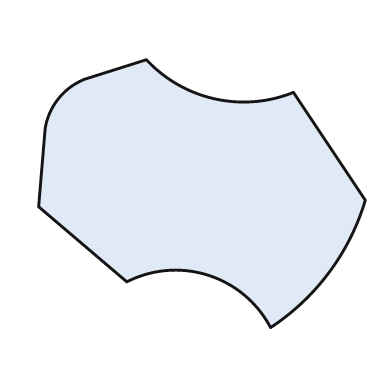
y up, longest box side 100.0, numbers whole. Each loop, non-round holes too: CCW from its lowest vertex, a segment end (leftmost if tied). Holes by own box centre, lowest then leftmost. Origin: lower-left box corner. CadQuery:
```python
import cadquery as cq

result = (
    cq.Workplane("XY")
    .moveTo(71.0, 0.0)
    .threePointArc((89.0, 17.0), (100.0, 39.0))
    .lineTo(78.0, 72.0)
    .threePointArc((54.0, 70.0), (33.0, 82.0))
    .lineTo(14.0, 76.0)
    .threePointArc((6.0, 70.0), (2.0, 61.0))
    .lineTo(0.0, 37.0)
    .lineTo(27.0, 14.0)
    .threePointArc((52.0, 16.0), (71.0, 0.0))
    .close()
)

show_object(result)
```